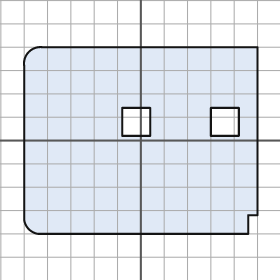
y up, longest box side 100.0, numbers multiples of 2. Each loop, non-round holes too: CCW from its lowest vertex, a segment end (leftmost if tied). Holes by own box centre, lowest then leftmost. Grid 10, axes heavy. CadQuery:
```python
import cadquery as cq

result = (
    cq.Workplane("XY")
    .moveTo(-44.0, -40.0)
    .lineTo(46.0, -40.0)
    .lineTo(46.0, -32.0)
    .lineTo(50.0, -32.0)
    .lineTo(50.0, 40.0)
    .lineTo(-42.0, 40.0)
    .threePointArc((-48.0, 38.0), (-50.0, 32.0))
    .lineTo(-50.0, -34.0)
    .threePointArc((-48.0, -38.0), (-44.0, -40.0))
    .close()
    .moveTo(-8.0, 2.0)
    .lineTo(4.0, 2.0)
    .lineTo(4.0, 14.0)
    .lineTo(-8.0, 14.0)
    .close()
    .moveTo(30.0, 2.0)
    .lineTo(42.0, 2.0)
    .lineTo(42.0, 14.0)
    .lineTo(30.0, 14.0)
    .close()
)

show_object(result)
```